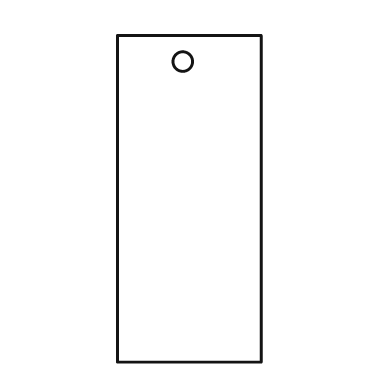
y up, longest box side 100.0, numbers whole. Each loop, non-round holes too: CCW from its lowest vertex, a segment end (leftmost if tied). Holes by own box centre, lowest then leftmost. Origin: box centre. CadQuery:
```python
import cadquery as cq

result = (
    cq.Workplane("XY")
    .moveTo(-22.0, -50.0)
    .lineTo(22.0, -50.0)
    .lineTo(22.0, 50.0)
    .lineTo(-22.0, 50.0)
    .close()
    .moveTo(-2.0, 42.0)
    .circle(3.0)
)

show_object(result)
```